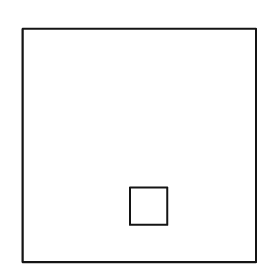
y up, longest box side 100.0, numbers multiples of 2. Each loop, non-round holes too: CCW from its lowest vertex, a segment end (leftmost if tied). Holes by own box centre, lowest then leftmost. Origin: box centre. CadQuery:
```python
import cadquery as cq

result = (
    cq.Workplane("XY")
    .moveTo(-50.0, -50.0)
    .lineTo(50.0, -50.0)
    .lineTo(50.0, 50.0)
    .lineTo(-50.0, 50.0)
    .close()
    .moveTo(-4.0, -34.0)
    .lineTo(12.0, -34.0)
    .lineTo(12.0, -18.0)
    .lineTo(-4.0, -18.0)
    .close()
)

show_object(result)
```